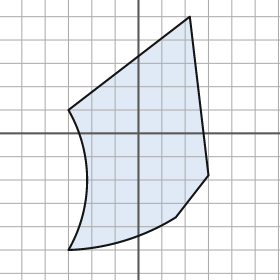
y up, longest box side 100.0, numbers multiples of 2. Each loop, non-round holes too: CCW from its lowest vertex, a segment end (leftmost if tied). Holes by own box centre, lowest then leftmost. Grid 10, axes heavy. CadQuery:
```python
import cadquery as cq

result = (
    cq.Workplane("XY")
    .moveTo(-30.0, -50.0)
    .threePointArc((-6.0, -46.0), (16.0, -36.0))
    .lineTo(30.0, -18.0)
    .lineTo(22.0, 50.0)
    .lineTo(-30.0, 10.0)
    .threePointArc((-22.0, -20.0), (-30.0, -50.0))
    .close()
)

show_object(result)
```